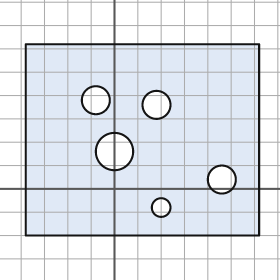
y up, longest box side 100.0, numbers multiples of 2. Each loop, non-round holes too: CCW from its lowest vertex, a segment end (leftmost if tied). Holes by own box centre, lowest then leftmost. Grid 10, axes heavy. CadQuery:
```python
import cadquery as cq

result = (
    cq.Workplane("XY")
    .moveTo(-38.0, -20.0)
    .lineTo(62.0, -20.0)
    .lineTo(62.0, 62.0)
    .lineTo(-38.0, 62.0)
    .close()
    .moveTo(20.0, -8.0)
    .circle(4.0)
    .moveTo(46.0, 4.0)
    .circle(6.0)
    .moveTo(0.0, 16.0)
    .circle(8.0)
    .moveTo(18.0, 36.0)
    .circle(6.0)
    .moveTo(-8.0, 38.0)
    .circle(6.0)
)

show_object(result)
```